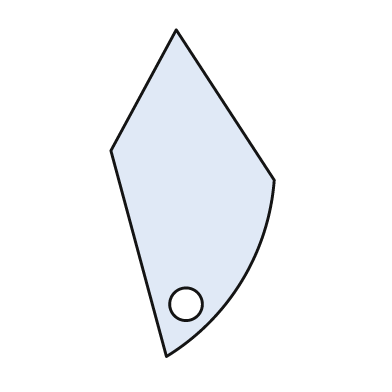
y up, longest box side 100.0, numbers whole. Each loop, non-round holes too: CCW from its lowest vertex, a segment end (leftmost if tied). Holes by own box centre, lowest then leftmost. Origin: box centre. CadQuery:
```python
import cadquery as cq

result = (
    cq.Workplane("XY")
    .moveTo(-8.0, -50.0)
    .threePointArc((15.0, -27.0), (25.0, 4.0))
    .lineTo(-5.0, 50.0)
    .lineTo(-25.0, 13.0)
    .close()
    .moveTo(-2.0, -34.0)
    .circle(5.0)
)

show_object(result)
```